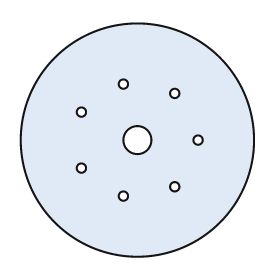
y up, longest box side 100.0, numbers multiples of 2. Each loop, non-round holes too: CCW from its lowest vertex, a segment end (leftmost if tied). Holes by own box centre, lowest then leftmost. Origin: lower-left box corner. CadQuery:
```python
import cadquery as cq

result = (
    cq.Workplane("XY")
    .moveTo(50.0, 50.0)
    .circle(50.0)
    .moveTo(44.0, 26.0)
    .circle(2.0)
    .moveTo(66.0, 30.0)
    .circle(2.0)
    .moveTo(26.0, 38.0)
    .circle(2.0)
    .moveTo(50.0, 50.0)
    .circle(6.0)
    .moveTo(76.0, 50.0)
    .circle(2.0)
    .moveTo(26.0, 62.0)
    .circle(2.0)
    .moveTo(66.0, 70.0)
    .circle(2.0)
    .moveTo(44.0, 74.0)
    .circle(2.0)
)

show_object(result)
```